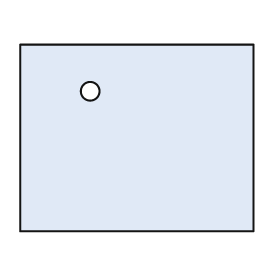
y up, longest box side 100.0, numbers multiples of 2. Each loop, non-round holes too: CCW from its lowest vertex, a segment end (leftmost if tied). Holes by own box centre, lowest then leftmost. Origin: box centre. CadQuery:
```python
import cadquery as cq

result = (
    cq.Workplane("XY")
    .moveTo(-50.0, -40.0)
    .lineTo(50.0, -40.0)
    .lineTo(50.0, 40.0)
    .lineTo(-50.0, 40.0)
    .close()
    .moveTo(-20.0, 20.0)
    .circle(4.0)
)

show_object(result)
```